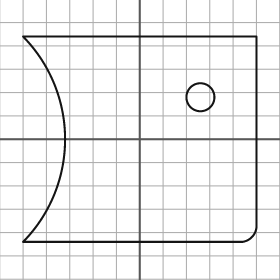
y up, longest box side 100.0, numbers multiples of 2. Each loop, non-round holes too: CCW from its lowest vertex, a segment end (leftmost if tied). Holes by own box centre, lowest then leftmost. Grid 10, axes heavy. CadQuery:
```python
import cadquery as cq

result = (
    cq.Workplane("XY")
    .moveTo(-50.0, -44.0)
    .lineTo(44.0, -44.0)
    .threePointArc((48.0, -42.0), (50.0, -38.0))
    .lineTo(50.0, 44.0)
    .lineTo(-50.0, 44.0)
    .threePointArc((-32.0, 0.0), (-50.0, -44.0))
    .close()
    .moveTo(26.0, 18.0)
    .circle(6.0)
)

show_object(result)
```